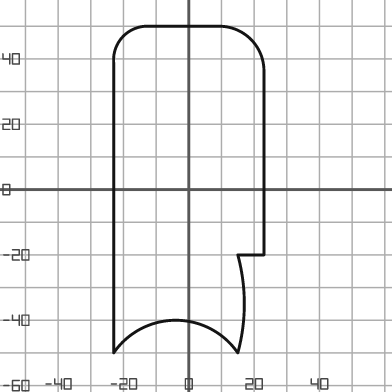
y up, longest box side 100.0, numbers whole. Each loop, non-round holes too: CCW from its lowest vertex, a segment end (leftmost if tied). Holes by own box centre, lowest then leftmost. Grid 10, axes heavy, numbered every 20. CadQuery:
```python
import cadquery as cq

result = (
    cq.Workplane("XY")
    .moveTo(-23.0, -50.0)
    .threePointArc((-4.0, -40.0), (15.0, -50.0))
    .threePointArc((17.0, -35.0), (15.0, -20.0))
    .lineTo(23.0, -20.0)
    .lineTo(23.0, 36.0)
    .threePointArc((19.0, 46.0), (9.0, 50.0))
    .lineTo(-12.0, 50.0)
    .threePointArc((-20.0, 47.0), (-23.0, 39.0))
    .close()
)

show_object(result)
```